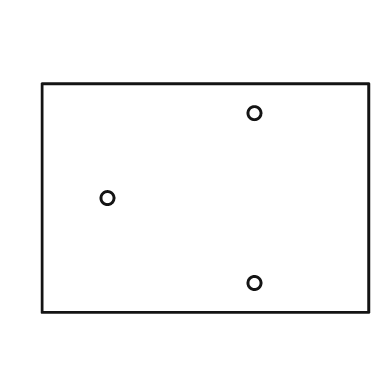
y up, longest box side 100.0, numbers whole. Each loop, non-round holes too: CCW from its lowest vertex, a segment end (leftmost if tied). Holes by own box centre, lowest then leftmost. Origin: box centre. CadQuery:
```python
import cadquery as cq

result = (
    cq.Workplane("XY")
    .moveTo(-50.0, -35.0)
    .lineTo(50.0, -35.0)
    .lineTo(50.0, 35.0)
    .lineTo(-50.0, 35.0)
    .close()
    .moveTo(15.0, -26.0)
    .circle(2.0)
    .moveTo(-30.0, 0.0)
    .circle(2.0)
    .moveTo(15.0, 26.0)
    .circle(2.0)
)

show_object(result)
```